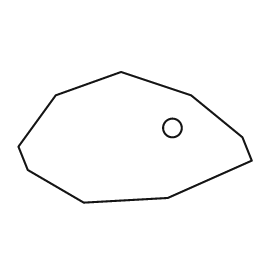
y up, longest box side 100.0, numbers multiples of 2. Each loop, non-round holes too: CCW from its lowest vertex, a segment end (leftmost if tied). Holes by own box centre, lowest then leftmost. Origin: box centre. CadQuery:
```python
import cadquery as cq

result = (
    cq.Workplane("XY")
    .moveTo(-22.0, -28.0)
    .lineTo(14.0, -26.0)
    .lineTo(50.0, -10.0)
    .lineTo(46.0, 0.0)
    .lineTo(24.0, 18.0)
    .lineTo(-6.0, 28.0)
    .lineTo(-34.0, 18.0)
    .lineTo(-50.0, -4.0)
    .lineTo(-46.0, -14.0)
    .close()
    .moveTo(16.0, 4.0)
    .circle(4.0)
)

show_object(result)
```